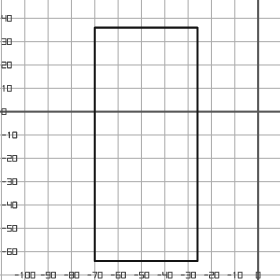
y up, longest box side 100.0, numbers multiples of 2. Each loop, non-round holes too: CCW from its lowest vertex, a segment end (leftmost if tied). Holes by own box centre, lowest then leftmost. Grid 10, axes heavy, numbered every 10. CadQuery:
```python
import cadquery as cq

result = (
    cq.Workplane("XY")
    .moveTo(-70.0, -64.0)
    .lineTo(-26.0, -64.0)
    .lineTo(-26.0, 36.0)
    .lineTo(-70.0, 36.0)
    .close()
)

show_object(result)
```